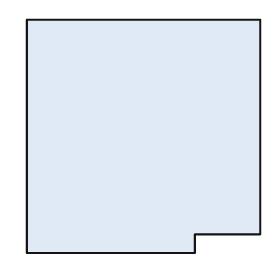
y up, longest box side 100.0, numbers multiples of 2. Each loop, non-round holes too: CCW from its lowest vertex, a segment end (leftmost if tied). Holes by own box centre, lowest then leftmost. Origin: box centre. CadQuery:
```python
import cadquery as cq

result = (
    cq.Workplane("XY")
    .moveTo(-50.0, -50.0)
    .lineTo(22.0, -50.0)
    .lineTo(22.0, -42.0)
    .lineTo(50.0, -42.0)
    .lineTo(50.0, 50.0)
    .lineTo(-50.0, 50.0)
    .close()
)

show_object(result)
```